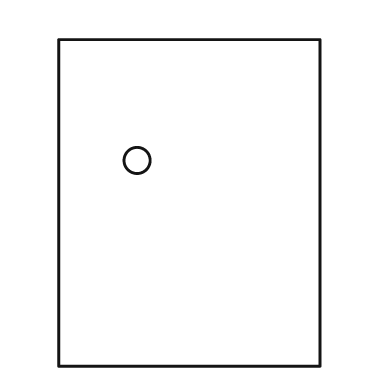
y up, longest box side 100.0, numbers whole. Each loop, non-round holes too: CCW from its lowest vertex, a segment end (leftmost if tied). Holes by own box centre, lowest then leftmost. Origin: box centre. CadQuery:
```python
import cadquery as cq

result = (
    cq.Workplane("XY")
    .moveTo(-40.0, -50.0)
    .lineTo(40.0, -50.0)
    .lineTo(40.0, 50.0)
    .lineTo(-40.0, 50.0)
    .close()
    .moveTo(-16.0, 13.0)
    .circle(4.0)
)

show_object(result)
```